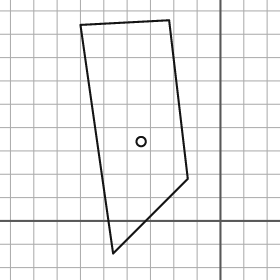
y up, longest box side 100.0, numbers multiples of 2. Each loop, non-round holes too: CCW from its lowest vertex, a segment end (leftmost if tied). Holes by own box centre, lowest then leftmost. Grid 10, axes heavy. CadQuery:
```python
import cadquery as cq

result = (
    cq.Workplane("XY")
    .moveTo(-46.0, -14.0)
    .lineTo(-14.0, 18.0)
    .lineTo(-22.0, 86.0)
    .lineTo(-60.0, 84.0)
    .close()
    .moveTo(-34.0, 34.0)
    .circle(2.0)
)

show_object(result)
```